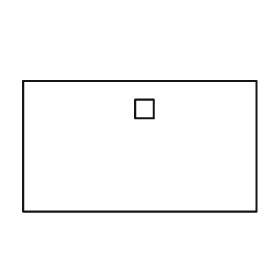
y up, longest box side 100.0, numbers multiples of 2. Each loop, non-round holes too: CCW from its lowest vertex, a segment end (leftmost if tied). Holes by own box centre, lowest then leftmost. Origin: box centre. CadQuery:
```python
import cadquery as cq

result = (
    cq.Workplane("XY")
    .moveTo(-50.0, -28.0)
    .lineTo(50.0, -28.0)
    .lineTo(50.0, 28.0)
    .lineTo(-50.0, 28.0)
    .close()
    .moveTo(-2.0, 12.0)
    .lineTo(6.0, 12.0)
    .lineTo(6.0, 20.0)
    .lineTo(-2.0, 20.0)
    .close()
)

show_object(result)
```